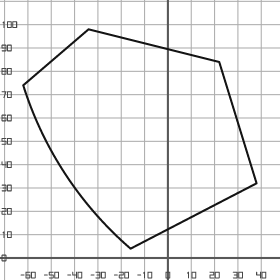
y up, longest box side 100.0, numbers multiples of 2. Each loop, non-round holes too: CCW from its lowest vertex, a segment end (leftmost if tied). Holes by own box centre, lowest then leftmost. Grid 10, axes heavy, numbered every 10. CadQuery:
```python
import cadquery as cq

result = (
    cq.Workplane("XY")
    .moveTo(-16.0, 4.0)
    .lineTo(38.0, 32.0)
    .lineTo(22.0, 84.0)
    .lineTo(-34.0, 98.0)
    .lineTo(-62.0, 74.0)
    .threePointArc((-44.0, 36.0), (-16.0, 4.0))
    .close()
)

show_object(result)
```